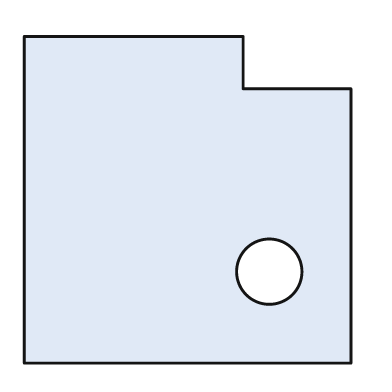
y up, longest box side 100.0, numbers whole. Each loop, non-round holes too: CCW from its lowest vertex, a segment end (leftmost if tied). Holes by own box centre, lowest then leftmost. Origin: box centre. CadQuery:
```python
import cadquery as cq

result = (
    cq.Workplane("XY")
    .moveTo(-50.0, -50.0)
    .lineTo(50.0, -50.0)
    .lineTo(50.0, 34.0)
    .lineTo(17.0, 34.0)
    .lineTo(17.0, 50.0)
    .lineTo(-50.0, 50.0)
    .close()
    .moveTo(25.0, -22.0)
    .circle(10.0)
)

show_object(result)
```